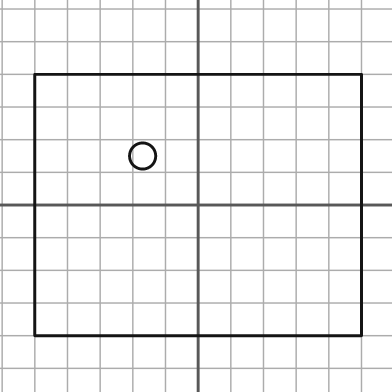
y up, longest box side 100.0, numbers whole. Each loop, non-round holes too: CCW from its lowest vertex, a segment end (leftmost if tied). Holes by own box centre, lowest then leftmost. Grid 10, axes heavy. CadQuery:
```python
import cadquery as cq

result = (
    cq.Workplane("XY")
    .moveTo(-50.0, -40.0)
    .lineTo(50.0, -40.0)
    .lineTo(50.0, 40.0)
    .lineTo(-50.0, 40.0)
    .close()
    .moveTo(-17.0, 15.0)
    .circle(4.0)
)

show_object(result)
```